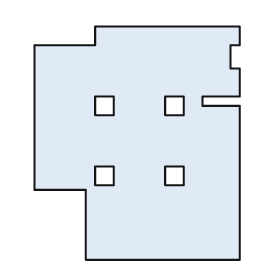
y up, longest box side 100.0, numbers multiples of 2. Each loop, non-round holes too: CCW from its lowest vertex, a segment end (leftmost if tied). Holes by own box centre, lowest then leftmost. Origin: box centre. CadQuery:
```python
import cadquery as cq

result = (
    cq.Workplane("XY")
    .moveTo(-22.0, -50.0)
    .lineTo(44.0, -50.0)
    .lineTo(44.0, 16.0)
    .lineTo(28.0, 16.0)
    .lineTo(28.0, 20.0)
    .lineTo(44.0, 20.0)
    .lineTo(44.0, 32.0)
    .lineTo(40.0, 32.0)
    .lineTo(40.0, 42.0)
    .lineTo(44.0, 42.0)
    .lineTo(44.0, 50.0)
    .lineTo(-18.0, 50.0)
    .lineTo(-18.0, 42.0)
    .lineTo(-44.0, 42.0)
    .lineTo(-44.0, -20.0)
    .lineTo(-22.0, -20.0)
    .close()
    .moveTo(-18.0, -18.0)
    .lineTo(-10.0, -18.0)
    .lineTo(-10.0, -10.0)
    .lineTo(-18.0, -10.0)
    .close()
    .moveTo(12.0, -18.0)
    .lineTo(20.0, -18.0)
    .lineTo(20.0, -10.0)
    .lineTo(12.0, -10.0)
    .close()
    .moveTo(-18.0, 12.0)
    .lineTo(-10.0, 12.0)
    .lineTo(-10.0, 20.0)
    .lineTo(-18.0, 20.0)
    .close()
    .moveTo(12.0, 12.0)
    .lineTo(20.0, 12.0)
    .lineTo(20.0, 20.0)
    .lineTo(12.0, 20.0)
    .close()
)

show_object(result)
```